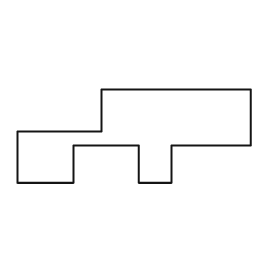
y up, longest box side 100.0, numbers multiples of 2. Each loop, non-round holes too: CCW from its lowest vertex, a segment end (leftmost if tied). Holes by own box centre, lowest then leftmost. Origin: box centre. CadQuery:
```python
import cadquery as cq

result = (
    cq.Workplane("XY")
    .moveTo(-50.0, -20.0)
    .lineTo(-26.0, -20.0)
    .lineTo(-26.0, -4.0)
    .lineTo(2.0, -4.0)
    .lineTo(2.0, -20.0)
    .lineTo(16.0, -20.0)
    .lineTo(16.0, -4.0)
    .lineTo(50.0, -4.0)
    .lineTo(50.0, 20.0)
    .lineTo(-14.0, 20.0)
    .lineTo(-14.0, 2.0)
    .lineTo(-50.0, 2.0)
    .close()
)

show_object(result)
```